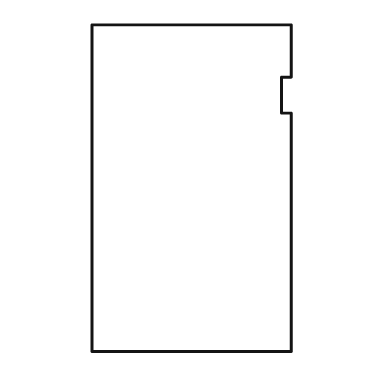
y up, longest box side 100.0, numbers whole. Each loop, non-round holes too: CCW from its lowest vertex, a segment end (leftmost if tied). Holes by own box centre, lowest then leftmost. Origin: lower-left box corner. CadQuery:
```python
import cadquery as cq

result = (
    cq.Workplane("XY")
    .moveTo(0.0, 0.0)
    .lineTo(61.0, 0.0)
    .lineTo(61.0, 73.0)
    .lineTo(58.0, 73.0)
    .lineTo(58.0, 84.0)
    .lineTo(61.0, 84.0)
    .lineTo(61.0, 100.0)
    .lineTo(0.0, 100.0)
    .close()
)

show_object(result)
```